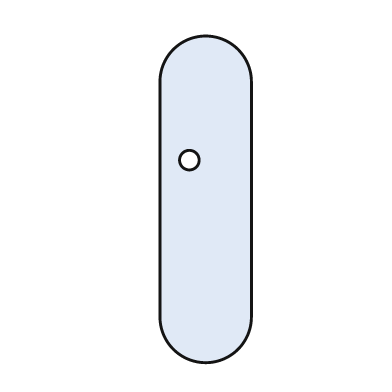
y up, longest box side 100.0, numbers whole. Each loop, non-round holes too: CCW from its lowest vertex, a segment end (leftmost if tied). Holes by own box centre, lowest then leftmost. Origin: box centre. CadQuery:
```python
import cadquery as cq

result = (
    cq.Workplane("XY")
    .moveTo(-14.0, -36.0)
    .threePointArc((0.0, -50.0), (14.0, -36.0))
    .lineTo(14.0, 36.0)
    .threePointArc((0.0, 50.0), (-14.0, 36.0))
    .close()
    .moveTo(-5.0, 12.0)
    .circle(3.0)
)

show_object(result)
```